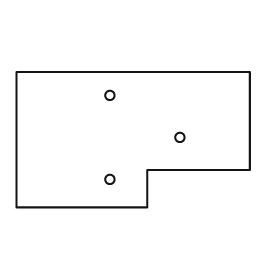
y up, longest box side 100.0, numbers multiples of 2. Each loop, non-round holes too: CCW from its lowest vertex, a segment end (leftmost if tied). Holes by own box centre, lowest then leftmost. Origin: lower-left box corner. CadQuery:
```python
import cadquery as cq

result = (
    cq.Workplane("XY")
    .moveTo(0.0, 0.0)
    .lineTo(56.0, 0.0)
    .lineTo(56.0, 16.0)
    .lineTo(100.0, 16.0)
    .lineTo(100.0, 58.0)
    .lineTo(0.0, 58.0)
    .close()
    .moveTo(40.0, 12.0)
    .circle(2.0)
    .moveTo(70.0, 30.0)
    .circle(2.0)
    .moveTo(40.0, 48.0)
    .circle(2.0)
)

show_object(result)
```